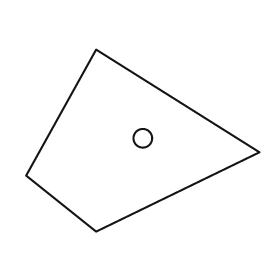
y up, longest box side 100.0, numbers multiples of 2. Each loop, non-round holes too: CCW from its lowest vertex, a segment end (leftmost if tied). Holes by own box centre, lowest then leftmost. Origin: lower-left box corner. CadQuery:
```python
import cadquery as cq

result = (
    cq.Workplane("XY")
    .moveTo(30.0, 0.0)
    .lineTo(100.0, 34.0)
    .lineTo(30.0, 78.0)
    .lineTo(0.0, 24.0)
    .close()
    .moveTo(50.0, 40.0)
    .circle(4.0)
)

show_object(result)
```